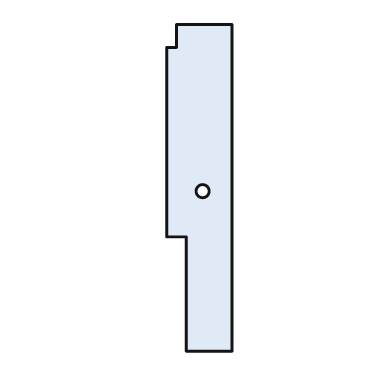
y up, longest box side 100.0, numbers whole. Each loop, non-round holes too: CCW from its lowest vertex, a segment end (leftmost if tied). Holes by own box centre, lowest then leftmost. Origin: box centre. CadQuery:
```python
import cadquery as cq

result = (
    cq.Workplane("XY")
    .moveTo(-4.0, -50.0)
    .lineTo(10.0, -50.0)
    .lineTo(10.0, 50.0)
    .lineTo(-7.0, 50.0)
    .lineTo(-7.0, 43.0)
    .lineTo(-10.0, 43.0)
    .lineTo(-10.0, -15.0)
    .lineTo(-4.0, -15.0)
    .close()
    .moveTo(1.0, -1.0)
    .circle(2.0)
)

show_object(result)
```